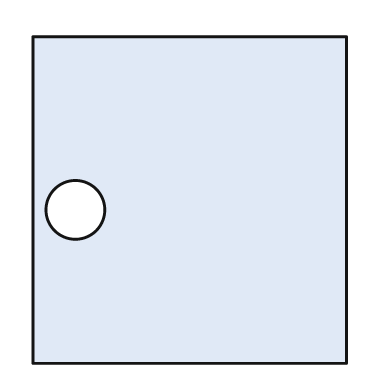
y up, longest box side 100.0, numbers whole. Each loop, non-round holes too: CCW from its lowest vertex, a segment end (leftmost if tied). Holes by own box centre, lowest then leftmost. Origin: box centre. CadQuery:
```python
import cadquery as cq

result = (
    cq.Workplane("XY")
    .moveTo(-48.0, -50.0)
    .lineTo(48.0, -50.0)
    .lineTo(48.0, 50.0)
    .lineTo(-48.0, 50.0)
    .close()
    .moveTo(-35.0, -3.0)
    .circle(9.0)
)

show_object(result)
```